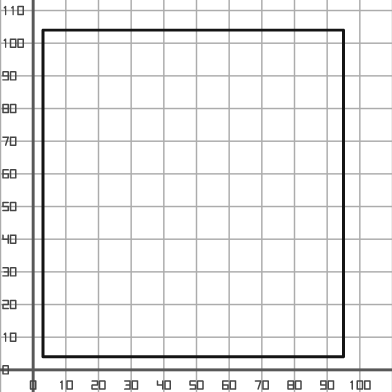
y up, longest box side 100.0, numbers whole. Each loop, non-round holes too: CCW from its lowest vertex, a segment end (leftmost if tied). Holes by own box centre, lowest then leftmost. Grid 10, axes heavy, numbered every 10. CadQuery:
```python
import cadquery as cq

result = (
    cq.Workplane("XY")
    .moveTo(3.0, 4.0)
    .lineTo(95.0, 4.0)
    .lineTo(95.0, 104.0)
    .lineTo(3.0, 104.0)
    .close()
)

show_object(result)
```